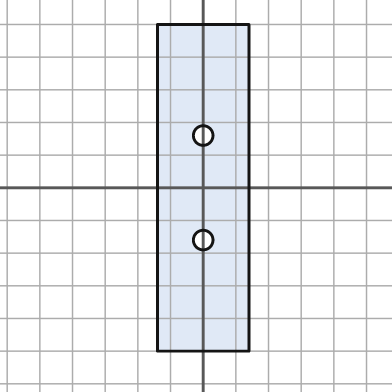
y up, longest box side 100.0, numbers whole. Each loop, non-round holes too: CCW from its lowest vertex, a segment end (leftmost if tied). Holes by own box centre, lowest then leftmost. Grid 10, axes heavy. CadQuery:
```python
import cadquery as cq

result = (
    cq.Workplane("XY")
    .moveTo(-14.0, -50.0)
    .lineTo(14.0, -50.0)
    .lineTo(14.0, 50.0)
    .lineTo(-14.0, 50.0)
    .close()
    .moveTo(0.0, -16.0)
    .circle(3.0)
    .moveTo(0.0, 16.0)
    .circle(3.0)
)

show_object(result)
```